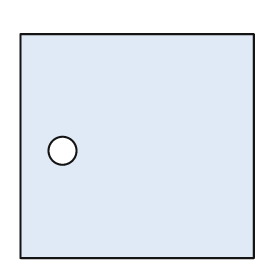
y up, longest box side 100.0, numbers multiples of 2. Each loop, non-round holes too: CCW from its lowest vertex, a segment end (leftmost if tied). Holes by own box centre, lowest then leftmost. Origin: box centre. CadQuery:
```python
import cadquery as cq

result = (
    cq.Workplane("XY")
    .moveTo(-50.0, -48.0)
    .lineTo(50.0, -48.0)
    .lineTo(50.0, 48.0)
    .lineTo(-50.0, 48.0)
    .close()
    .moveTo(-32.0, -2.0)
    .circle(6.0)
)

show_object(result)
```